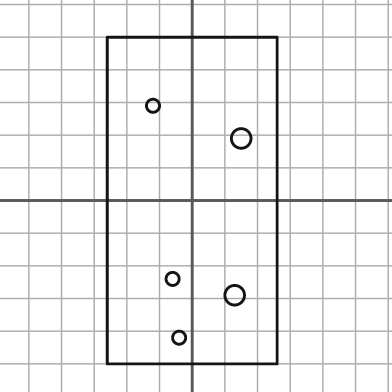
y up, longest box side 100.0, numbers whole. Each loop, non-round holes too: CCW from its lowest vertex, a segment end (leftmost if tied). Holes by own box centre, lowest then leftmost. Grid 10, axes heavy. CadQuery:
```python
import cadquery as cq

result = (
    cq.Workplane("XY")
    .moveTo(-26.0, -50.0)
    .lineTo(26.0, -50.0)
    .lineTo(26.0, 50.0)
    .lineTo(-26.0, 50.0)
    .close()
    .moveTo(-4.0, -42.0)
    .circle(2.0)
    .moveTo(13.0, -29.0)
    .circle(3.0)
    .moveTo(-6.0, -24.0)
    .circle(2.0)
    .moveTo(15.0, 19.0)
    .circle(3.0)
    .moveTo(-12.0, 29.0)
    .circle(2.0)
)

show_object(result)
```